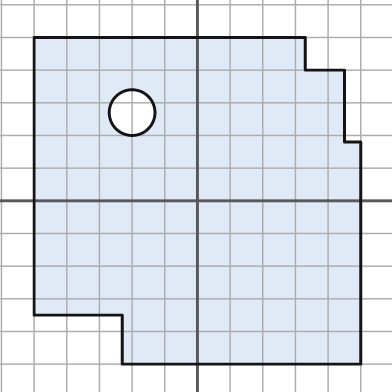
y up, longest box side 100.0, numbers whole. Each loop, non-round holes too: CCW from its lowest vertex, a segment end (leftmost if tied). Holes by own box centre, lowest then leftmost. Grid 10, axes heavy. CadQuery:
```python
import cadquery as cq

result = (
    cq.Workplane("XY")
    .moveTo(-23.0, -50.0)
    .lineTo(50.0, -50.0)
    .lineTo(50.0, 18.0)
    .lineTo(45.0, 18.0)
    .lineTo(45.0, 40.0)
    .lineTo(33.0, 40.0)
    .lineTo(33.0, 50.0)
    .lineTo(-50.0, 50.0)
    .lineTo(-50.0, -35.0)
    .lineTo(-23.0, -35.0)
    .close()
    .moveTo(-20.0, 27.0)
    .circle(7.0)
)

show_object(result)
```